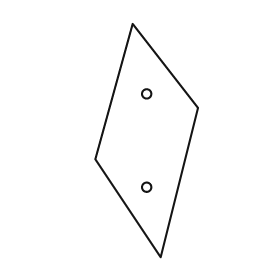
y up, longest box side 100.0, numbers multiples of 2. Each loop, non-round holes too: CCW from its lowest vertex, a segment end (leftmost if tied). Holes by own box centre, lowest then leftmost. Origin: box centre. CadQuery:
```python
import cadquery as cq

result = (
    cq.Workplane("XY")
    .moveTo(6.0, -50.0)
    .lineTo(22.0, 14.0)
    .lineTo(-6.0, 50.0)
    .lineTo(-22.0, -8.0)
    .close()
    .moveTo(0.0, -20.0)
    .circle(2.0)
    .moveTo(0.0, 20.0)
    .circle(2.0)
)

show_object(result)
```